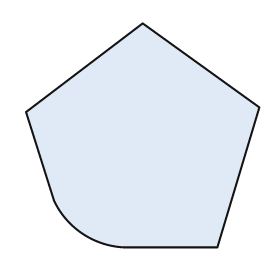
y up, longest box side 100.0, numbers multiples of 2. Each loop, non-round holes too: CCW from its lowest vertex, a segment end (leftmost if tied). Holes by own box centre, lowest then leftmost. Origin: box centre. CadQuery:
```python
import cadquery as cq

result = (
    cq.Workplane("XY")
    .moveTo(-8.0, -48.0)
    .lineTo(32.0, -48.0)
    .lineTo(50.0, 12.0)
    .lineTo(0.0, 48.0)
    .lineTo(-50.0, 10.0)
    .lineTo(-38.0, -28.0)
    .threePointArc((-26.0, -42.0), (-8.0, -48.0))
    .close()
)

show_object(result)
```